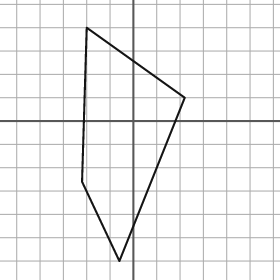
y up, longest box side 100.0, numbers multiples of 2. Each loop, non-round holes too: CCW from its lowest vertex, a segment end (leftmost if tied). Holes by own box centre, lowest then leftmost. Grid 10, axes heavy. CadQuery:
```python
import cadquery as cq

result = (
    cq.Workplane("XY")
    .moveTo(-6.0, -60.0)
    .lineTo(22.0, 10.0)
    .lineTo(-20.0, 40.0)
    .lineTo(-22.0, -26.0)
    .close()
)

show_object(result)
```